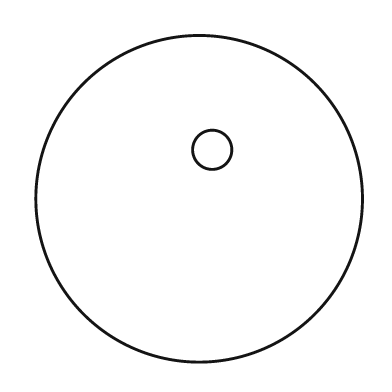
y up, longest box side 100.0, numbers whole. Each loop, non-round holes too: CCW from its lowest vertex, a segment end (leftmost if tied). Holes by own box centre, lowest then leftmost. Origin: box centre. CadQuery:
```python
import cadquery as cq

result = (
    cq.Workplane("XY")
    .moveTo(0.0, 0.0)
    .circle(50.0)
    .moveTo(4.0, 15.0)
    .circle(6.0)
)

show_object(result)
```